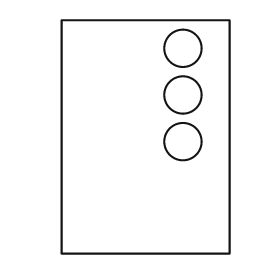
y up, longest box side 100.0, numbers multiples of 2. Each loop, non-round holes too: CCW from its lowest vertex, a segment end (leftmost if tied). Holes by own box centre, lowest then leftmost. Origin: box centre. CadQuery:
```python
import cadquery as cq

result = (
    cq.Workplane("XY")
    .moveTo(-36.0, -50.0)
    .lineTo(36.0, -50.0)
    .lineTo(36.0, 50.0)
    .lineTo(-36.0, 50.0)
    .close()
    .moveTo(16.0, -2.0)
    .circle(8.0)
    .moveTo(16.0, 18.0)
    .circle(8.0)
    .moveTo(16.0, 38.0)
    .circle(8.0)
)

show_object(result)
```